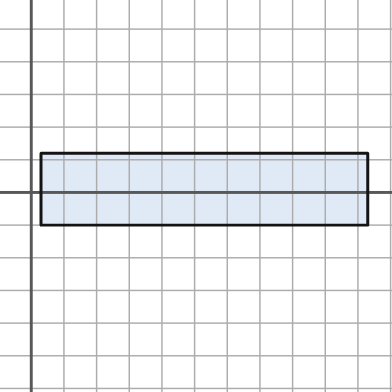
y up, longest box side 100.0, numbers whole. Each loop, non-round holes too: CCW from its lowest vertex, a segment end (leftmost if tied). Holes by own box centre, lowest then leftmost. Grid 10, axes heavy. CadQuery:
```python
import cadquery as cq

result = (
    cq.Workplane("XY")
    .moveTo(3.0, -10.0)
    .lineTo(103.0, -10.0)
    .lineTo(103.0, 12.0)
    .lineTo(3.0, 12.0)
    .close()
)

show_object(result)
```